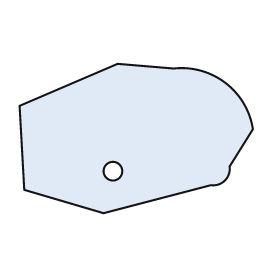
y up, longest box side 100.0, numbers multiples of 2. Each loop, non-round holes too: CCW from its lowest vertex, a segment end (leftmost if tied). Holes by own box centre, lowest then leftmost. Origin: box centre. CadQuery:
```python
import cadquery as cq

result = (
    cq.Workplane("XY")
    .moveTo(-14.0, -32.0)
    .lineTo(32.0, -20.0)
    .threePointArc((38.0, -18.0), (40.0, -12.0))
    .lineTo(50.0, 4.0)
    .threePointArc((38.0, 24.0), (16.0, 30.0))
    .lineTo(-8.0, 32.0)
    .lineTo(-50.0, 14.0)
    .lineTo(-48.0, -22.0)
    .close()
    .moveTo(-10.0, -14.0)
    .circle(4.0)
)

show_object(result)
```